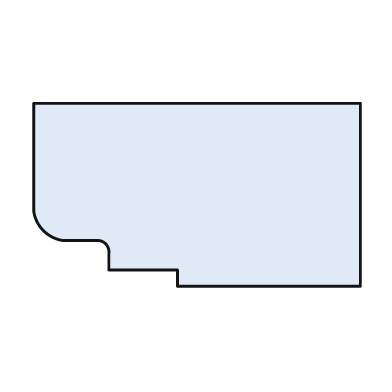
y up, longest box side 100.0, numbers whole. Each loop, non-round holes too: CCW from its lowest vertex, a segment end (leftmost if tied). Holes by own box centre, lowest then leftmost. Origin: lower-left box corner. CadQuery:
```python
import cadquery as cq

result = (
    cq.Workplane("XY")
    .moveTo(44.0, 0.0)
    .lineTo(100.0, 0.0)
    .lineTo(100.0, 56.0)
    .lineTo(0.0, 56.0)
    .lineTo(0.0, 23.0)
    .threePointArc((3.0, 17.0), (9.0, 14.0))
    .lineTo(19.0, 14.0)
    .threePointArc((22.0, 13.0), (23.0, 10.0))
    .lineTo(23.0, 5.0)
    .lineTo(44.0, 5.0)
    .close()
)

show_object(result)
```